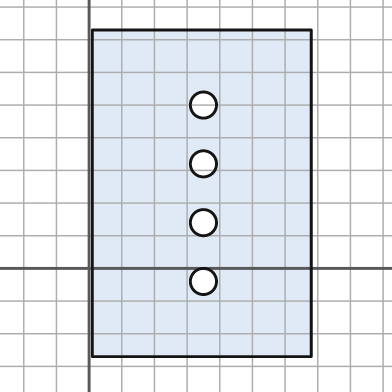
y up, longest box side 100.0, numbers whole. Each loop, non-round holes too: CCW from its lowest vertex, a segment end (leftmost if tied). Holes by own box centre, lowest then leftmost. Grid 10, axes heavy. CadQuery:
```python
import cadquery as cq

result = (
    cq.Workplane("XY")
    .moveTo(1.0, -27.0)
    .lineTo(68.0, -27.0)
    .lineTo(68.0, 73.0)
    .lineTo(1.0, 73.0)
    .close()
    .moveTo(35.0, -4.0)
    .circle(4.0)
    .moveTo(35.0, 14.0)
    .circle(4.0)
    .moveTo(35.0, 32.0)
    .circle(4.0)
    .moveTo(35.0, 50.0)
    .circle(4.0)
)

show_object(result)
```